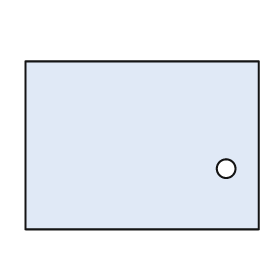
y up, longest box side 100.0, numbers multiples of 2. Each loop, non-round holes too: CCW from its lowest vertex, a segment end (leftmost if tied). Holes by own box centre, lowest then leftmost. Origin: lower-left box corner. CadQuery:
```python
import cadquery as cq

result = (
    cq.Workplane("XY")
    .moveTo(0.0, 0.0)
    .lineTo(100.0, 0.0)
    .lineTo(100.0, 72.0)
    .lineTo(0.0, 72.0)
    .close()
    .moveTo(86.0, 26.0)
    .circle(4.0)
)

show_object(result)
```